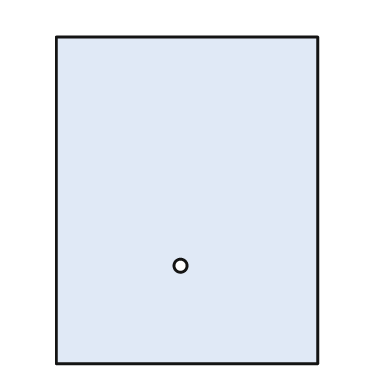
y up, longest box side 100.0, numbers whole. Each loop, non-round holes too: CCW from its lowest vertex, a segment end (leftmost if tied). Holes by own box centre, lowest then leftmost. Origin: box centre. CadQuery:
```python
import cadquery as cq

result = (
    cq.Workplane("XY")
    .moveTo(-40.0, -50.0)
    .lineTo(40.0, -50.0)
    .lineTo(40.0, 50.0)
    .lineTo(-40.0, 50.0)
    .close()
    .moveTo(-2.0, -20.0)
    .circle(2.0)
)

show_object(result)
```